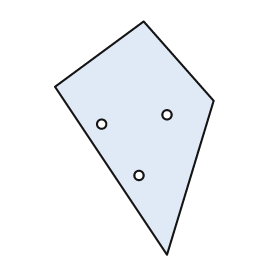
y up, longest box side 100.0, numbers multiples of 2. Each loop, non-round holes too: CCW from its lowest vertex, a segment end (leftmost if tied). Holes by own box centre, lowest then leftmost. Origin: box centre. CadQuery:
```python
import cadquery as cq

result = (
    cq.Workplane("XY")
    .moveTo(14.0, -50.0)
    .lineTo(34.0, 16.0)
    .lineTo(4.0, 50.0)
    .lineTo(-34.0, 22.0)
    .close()
    .moveTo(2.0, -16.0)
    .circle(2.0)
    .moveTo(-14.0, 6.0)
    .circle(2.0)
    .moveTo(14.0, 10.0)
    .circle(2.0)
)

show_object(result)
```